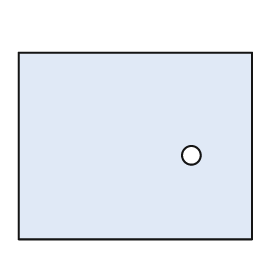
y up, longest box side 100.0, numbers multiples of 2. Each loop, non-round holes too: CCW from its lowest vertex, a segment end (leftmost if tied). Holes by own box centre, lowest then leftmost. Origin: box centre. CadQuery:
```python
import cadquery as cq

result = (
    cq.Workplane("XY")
    .moveTo(-50.0, -40.0)
    .lineTo(50.0, -40.0)
    .lineTo(50.0, 40.0)
    .lineTo(-50.0, 40.0)
    .close()
    .moveTo(24.0, -4.0)
    .circle(4.0)
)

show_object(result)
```